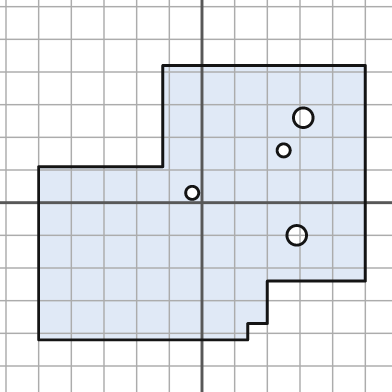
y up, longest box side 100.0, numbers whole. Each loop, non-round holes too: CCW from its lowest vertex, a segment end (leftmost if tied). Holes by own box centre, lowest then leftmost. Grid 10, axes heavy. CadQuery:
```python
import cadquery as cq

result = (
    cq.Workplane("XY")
    .moveTo(-50.0, -42.0)
    .lineTo(14.0, -42.0)
    .lineTo(14.0, -37.0)
    .lineTo(20.0, -37.0)
    .lineTo(20.0, -24.0)
    .lineTo(50.0, -24.0)
    .lineTo(50.0, 42.0)
    .lineTo(-12.0, 42.0)
    .lineTo(-12.0, 11.0)
    .lineTo(-50.0, 11.0)
    .close()
    .moveTo(29.0, -10.0)
    .circle(3.0)
    .moveTo(-3.0, 3.0)
    .circle(2.0)
    .moveTo(25.0, 16.0)
    .circle(2.0)
    .moveTo(31.0, 26.0)
    .circle(3.0)
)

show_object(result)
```